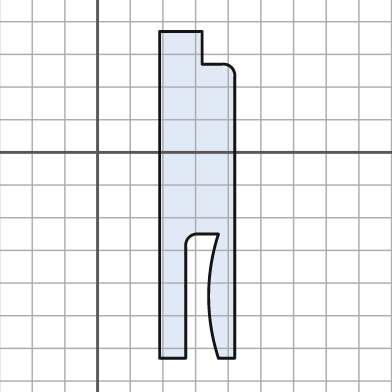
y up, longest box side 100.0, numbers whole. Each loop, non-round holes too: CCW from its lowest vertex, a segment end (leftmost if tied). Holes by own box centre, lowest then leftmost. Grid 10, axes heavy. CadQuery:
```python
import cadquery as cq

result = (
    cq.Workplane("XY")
    .moveTo(19.0, -63.0)
    .lineTo(27.0, -63.0)
    .lineTo(27.0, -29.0)
    .threePointArc((28.0, -26.0), (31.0, -25.0))
    .lineTo(37.0, -25.0)
    .threePointArc((34.0, -44.0), (37.0, -63.0))
    .lineTo(42.0, -63.0)
    .lineTo(42.0, 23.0)
    .threePointArc((41.0, 26.0), (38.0, 27.0))
    .lineTo(32.0, 27.0)
    .lineTo(32.0, 37.0)
    .lineTo(19.0, 37.0)
    .close()
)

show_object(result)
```